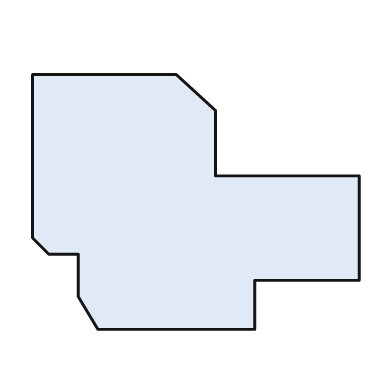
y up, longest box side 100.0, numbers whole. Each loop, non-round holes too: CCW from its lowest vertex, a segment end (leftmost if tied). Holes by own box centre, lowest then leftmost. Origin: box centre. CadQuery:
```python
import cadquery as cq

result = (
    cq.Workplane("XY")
    .moveTo(-30.0, -39.0)
    .lineTo(18.0, -39.0)
    .lineTo(18.0, -24.0)
    .lineTo(50.0, -24.0)
    .lineTo(50.0, 8.0)
    .lineTo(6.0, 8.0)
    .lineTo(6.0, 28.0)
    .lineTo(-6.0, 39.0)
    .lineTo(-50.0, 39.0)
    .lineTo(-50.0, -11.0)
    .lineTo(-45.0, -16.0)
    .lineTo(-36.0, -16.0)
    .lineTo(-36.0, -29.0)
    .close()
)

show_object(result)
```